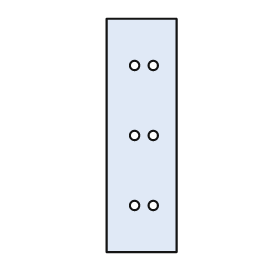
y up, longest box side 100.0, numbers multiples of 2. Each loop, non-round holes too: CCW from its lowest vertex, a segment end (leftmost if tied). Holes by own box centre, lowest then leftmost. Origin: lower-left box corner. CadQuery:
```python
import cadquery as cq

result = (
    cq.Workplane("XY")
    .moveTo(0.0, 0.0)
    .lineTo(30.0, 0.0)
    .lineTo(30.0, 100.0)
    .lineTo(0.0, 100.0)
    .close()
    .moveTo(12.0, 20.0)
    .circle(2.0)
    .moveTo(20.0, 20.0)
    .circle(2.0)
    .moveTo(12.0, 50.0)
    .circle(2.0)
    .moveTo(20.0, 50.0)
    .circle(2.0)
    .moveTo(12.0, 80.0)
    .circle(2.0)
    .moveTo(20.0, 80.0)
    .circle(2.0)
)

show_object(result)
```